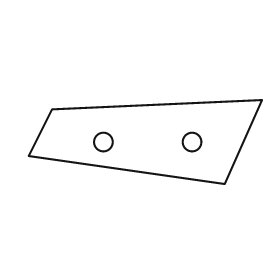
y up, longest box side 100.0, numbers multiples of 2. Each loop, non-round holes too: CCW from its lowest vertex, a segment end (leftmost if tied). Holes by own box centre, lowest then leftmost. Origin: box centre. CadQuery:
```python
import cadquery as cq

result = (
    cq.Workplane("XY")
    .moveTo(34.0, -18.0)
    .lineTo(50.0, 18.0)
    .lineTo(-40.0, 14.0)
    .lineTo(-50.0, -6.0)
    .close()
    .moveTo(-18.0, 0.0)
    .circle(4.0)
    .moveTo(20.0, 0.0)
    .circle(4.0)
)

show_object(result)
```